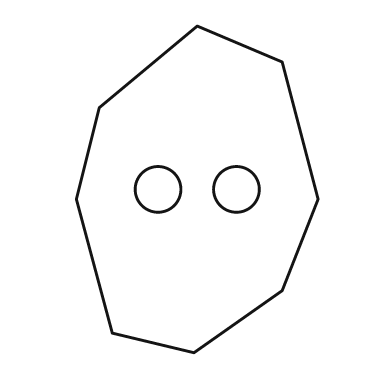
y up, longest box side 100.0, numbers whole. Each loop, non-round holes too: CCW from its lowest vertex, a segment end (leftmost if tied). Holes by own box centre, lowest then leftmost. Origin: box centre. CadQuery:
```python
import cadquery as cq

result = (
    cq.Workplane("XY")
    .moveTo(-1.0, -50.0)
    .lineTo(26.0, -31.0)
    .lineTo(37.0, -3.0)
    .lineTo(26.0, 39.0)
    .lineTo(0.0, 50.0)
    .lineTo(-30.0, 25.0)
    .lineTo(-37.0, -3.0)
    .lineTo(-26.0, -44.0)
    .close()
    .moveTo(-12.0, 0.0)
    .circle(7.0)
    .moveTo(12.0, 0.0)
    .circle(7.0)
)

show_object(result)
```